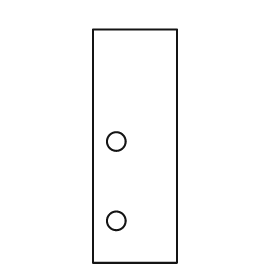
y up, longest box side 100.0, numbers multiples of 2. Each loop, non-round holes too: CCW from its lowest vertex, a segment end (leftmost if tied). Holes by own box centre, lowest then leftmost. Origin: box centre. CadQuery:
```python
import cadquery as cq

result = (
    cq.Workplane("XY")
    .moveTo(-18.0, -50.0)
    .lineTo(18.0, -50.0)
    .lineTo(18.0, 50.0)
    .lineTo(-18.0, 50.0)
    .close()
    .moveTo(-8.0, -32.0)
    .circle(4.0)
    .moveTo(-8.0, 2.0)
    .circle(4.0)
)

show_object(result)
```